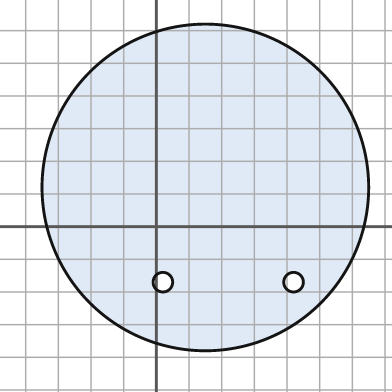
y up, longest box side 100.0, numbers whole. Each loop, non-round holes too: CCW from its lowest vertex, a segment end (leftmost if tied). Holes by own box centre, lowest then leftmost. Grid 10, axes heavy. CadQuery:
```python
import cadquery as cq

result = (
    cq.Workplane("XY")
    .moveTo(15.0, 12.0)
    .circle(50.0)
    .moveTo(2.0, -17.0)
    .circle(3.0)
    .moveTo(42.0, -17.0)
    .circle(3.0)
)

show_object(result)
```